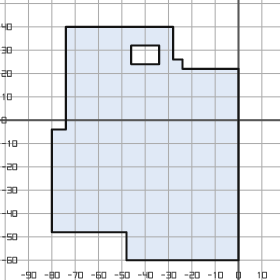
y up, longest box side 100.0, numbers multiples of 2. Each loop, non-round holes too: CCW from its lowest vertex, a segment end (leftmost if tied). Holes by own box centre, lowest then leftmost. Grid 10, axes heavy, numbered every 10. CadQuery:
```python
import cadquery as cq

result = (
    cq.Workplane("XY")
    .moveTo(-48.0, -60.0)
    .lineTo(0.0, -60.0)
    .lineTo(0.0, 22.0)
    .lineTo(-24.0, 22.0)
    .lineTo(-24.0, 26.0)
    .lineTo(-28.0, 26.0)
    .lineTo(-28.0, 40.0)
    .lineTo(-74.0, 40.0)
    .lineTo(-74.0, -4.0)
    .lineTo(-80.0, -4.0)
    .lineTo(-80.0, -48.0)
    .lineTo(-48.0, -48.0)
    .close()
    .moveTo(-46.0, 24.0)
    .lineTo(-34.0, 24.0)
    .lineTo(-34.0, 32.0)
    .lineTo(-46.0, 32.0)
    .close()
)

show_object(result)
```